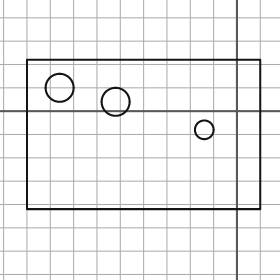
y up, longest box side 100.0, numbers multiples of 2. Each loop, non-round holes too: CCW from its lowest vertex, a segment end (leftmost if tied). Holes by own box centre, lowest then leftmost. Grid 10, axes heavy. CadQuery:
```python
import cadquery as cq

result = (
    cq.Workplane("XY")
    .moveTo(-90.0, -42.0)
    .lineTo(10.0, -42.0)
    .lineTo(10.0, 22.0)
    .lineTo(-90.0, 22.0)
    .close()
    .moveTo(-14.0, -8.0)
    .circle(4.0)
    .moveTo(-52.0, 4.0)
    .circle(6.0)
    .moveTo(-76.0, 10.0)
    .circle(6.0)
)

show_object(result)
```